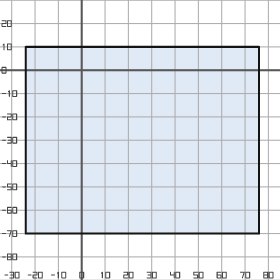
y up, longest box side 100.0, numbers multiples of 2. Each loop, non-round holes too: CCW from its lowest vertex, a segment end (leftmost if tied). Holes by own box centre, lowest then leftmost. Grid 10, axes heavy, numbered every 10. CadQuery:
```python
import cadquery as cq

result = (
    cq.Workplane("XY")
    .moveTo(-24.0, -70.0)
    .lineTo(76.0, -70.0)
    .lineTo(76.0, 10.0)
    .lineTo(-24.0, 10.0)
    .close()
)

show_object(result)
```